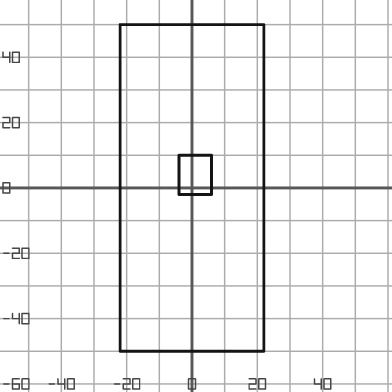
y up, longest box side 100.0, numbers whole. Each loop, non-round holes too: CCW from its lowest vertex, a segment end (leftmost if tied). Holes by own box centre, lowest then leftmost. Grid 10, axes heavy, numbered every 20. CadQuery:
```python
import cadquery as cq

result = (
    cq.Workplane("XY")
    .moveTo(-22.0, -50.0)
    .lineTo(22.0, -50.0)
    .lineTo(22.0, 50.0)
    .lineTo(-22.0, 50.0)
    .close()
    .moveTo(-4.0, -2.0)
    .lineTo(6.0, -2.0)
    .lineTo(6.0, 10.0)
    .lineTo(-4.0, 10.0)
    .close()
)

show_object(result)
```